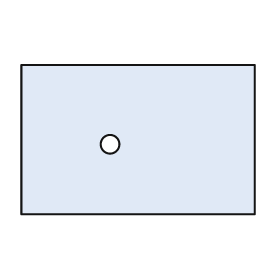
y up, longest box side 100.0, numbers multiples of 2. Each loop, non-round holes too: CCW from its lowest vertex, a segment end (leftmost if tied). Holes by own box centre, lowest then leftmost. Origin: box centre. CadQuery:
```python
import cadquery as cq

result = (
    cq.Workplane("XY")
    .moveTo(-50.0, -32.0)
    .lineTo(50.0, -32.0)
    .lineTo(50.0, 32.0)
    .lineTo(-50.0, 32.0)
    .close()
    .moveTo(-12.0, -2.0)
    .circle(4.0)
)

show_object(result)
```